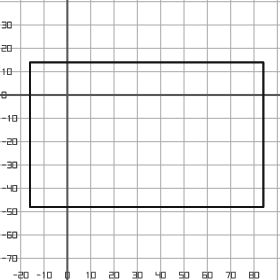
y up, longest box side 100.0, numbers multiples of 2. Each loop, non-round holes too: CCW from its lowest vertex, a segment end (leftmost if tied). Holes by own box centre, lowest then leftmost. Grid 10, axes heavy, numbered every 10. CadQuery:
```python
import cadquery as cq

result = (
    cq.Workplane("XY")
    .moveTo(-16.0, -48.0)
    .lineTo(84.0, -48.0)
    .lineTo(84.0, 14.0)
    .lineTo(-16.0, 14.0)
    .close()
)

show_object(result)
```